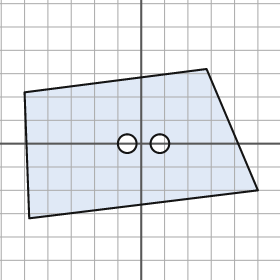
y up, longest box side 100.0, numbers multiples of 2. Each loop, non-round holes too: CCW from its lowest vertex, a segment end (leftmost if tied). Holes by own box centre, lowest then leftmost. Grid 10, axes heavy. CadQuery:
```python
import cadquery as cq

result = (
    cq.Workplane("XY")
    .moveTo(-48.0, -32.0)
    .lineTo(50.0, -20.0)
    .lineTo(28.0, 32.0)
    .lineTo(-50.0, 22.0)
    .close()
    .moveTo(-6.0, 0.0)
    .circle(4.0)
    .moveTo(8.0, 0.0)
    .circle(4.0)
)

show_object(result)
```